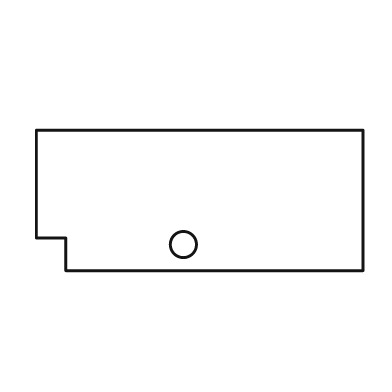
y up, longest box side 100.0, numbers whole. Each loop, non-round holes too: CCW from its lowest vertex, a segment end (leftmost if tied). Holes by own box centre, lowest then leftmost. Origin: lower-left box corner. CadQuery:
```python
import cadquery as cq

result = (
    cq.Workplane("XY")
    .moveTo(9.0, 0.0)
    .lineTo(100.0, 0.0)
    .lineTo(100.0, 43.0)
    .lineTo(0.0, 43.0)
    .lineTo(0.0, 10.0)
    .lineTo(9.0, 10.0)
    .close()
    .moveTo(45.0, 8.0)
    .circle(4.0)
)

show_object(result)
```